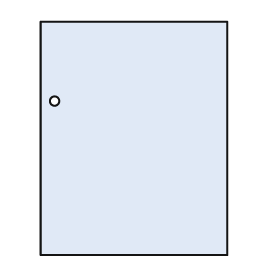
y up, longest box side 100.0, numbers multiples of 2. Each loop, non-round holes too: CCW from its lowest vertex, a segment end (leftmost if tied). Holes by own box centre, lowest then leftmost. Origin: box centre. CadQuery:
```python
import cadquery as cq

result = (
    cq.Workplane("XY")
    .moveTo(-40.0, -50.0)
    .lineTo(40.0, -50.0)
    .lineTo(40.0, 50.0)
    .lineTo(-40.0, 50.0)
    .close()
    .moveTo(-34.0, 16.0)
    .circle(2.0)
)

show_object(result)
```